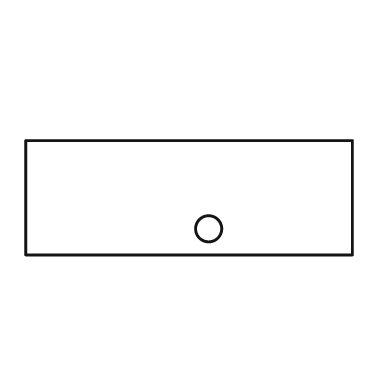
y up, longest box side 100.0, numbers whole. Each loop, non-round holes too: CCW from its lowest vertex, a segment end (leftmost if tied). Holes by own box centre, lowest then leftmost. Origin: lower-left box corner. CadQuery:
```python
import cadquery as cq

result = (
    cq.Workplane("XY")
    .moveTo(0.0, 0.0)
    .lineTo(100.0, 0.0)
    .lineTo(100.0, 35.0)
    .lineTo(0.0, 35.0)
    .close()
    .moveTo(56.0, 8.0)
    .circle(4.0)
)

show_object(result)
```